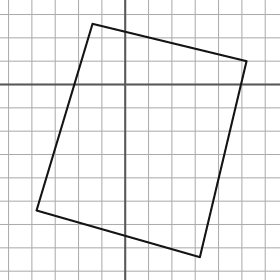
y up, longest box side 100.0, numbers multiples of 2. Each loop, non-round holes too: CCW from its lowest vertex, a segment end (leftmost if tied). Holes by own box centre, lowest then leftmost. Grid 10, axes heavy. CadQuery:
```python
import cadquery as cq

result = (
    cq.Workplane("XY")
    .moveTo(32.0, -74.0)
    .lineTo(52.0, 10.0)
    .lineTo(-14.0, 26.0)
    .lineTo(-38.0, -54.0)
    .close()
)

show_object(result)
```